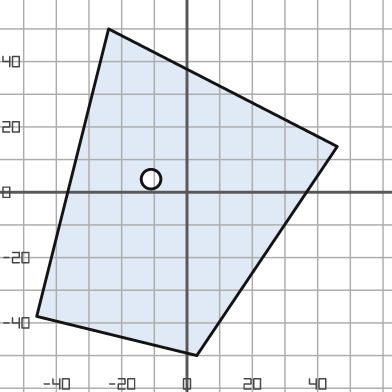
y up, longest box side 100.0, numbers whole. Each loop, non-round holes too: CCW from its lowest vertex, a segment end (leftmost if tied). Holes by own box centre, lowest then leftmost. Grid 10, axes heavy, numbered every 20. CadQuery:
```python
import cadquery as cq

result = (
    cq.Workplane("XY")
    .moveTo(3.0, -50.0)
    .lineTo(46.0, 14.0)
    .lineTo(-24.0, 50.0)
    .lineTo(-46.0, -38.0)
    .close()
    .moveTo(-11.0, 4.0)
    .circle(3.0)
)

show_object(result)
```